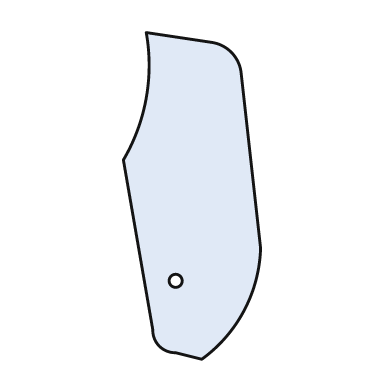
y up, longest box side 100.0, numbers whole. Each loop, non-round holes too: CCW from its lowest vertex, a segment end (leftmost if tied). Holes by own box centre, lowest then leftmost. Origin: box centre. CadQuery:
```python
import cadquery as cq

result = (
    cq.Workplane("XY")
    .moveTo(3.0, -50.0)
    .threePointArc((16.0, -35.0), (21.0, -16.0))
    .lineTo(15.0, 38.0)
    .threePointArc((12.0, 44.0), (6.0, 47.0))
    .lineTo(-14.0, 50.0)
    .threePointArc((-14.0, 30.0), (-21.0, 11.0))
    .lineTo(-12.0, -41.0)
    .threePointArc((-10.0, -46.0), (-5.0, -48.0))
    .close()
    .moveTo(-5.0, -26.0)
    .circle(2.0)
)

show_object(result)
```